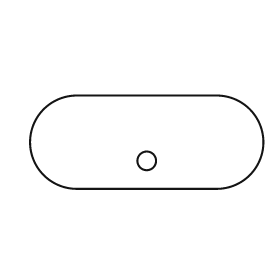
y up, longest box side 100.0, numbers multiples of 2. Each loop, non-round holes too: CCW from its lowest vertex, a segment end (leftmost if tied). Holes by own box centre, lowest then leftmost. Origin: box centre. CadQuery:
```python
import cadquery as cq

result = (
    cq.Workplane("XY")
    .moveTo(-30.0, -20.0)
    .lineTo(30.0, -20.0)
    .threePointArc((50.0, 0.0), (30.0, 20.0))
    .lineTo(-30.0, 20.0)
    .threePointArc((-50.0, 0.0), (-30.0, -20.0))
    .close()
    .moveTo(0.0, -8.0)
    .circle(4.0)
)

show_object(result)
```